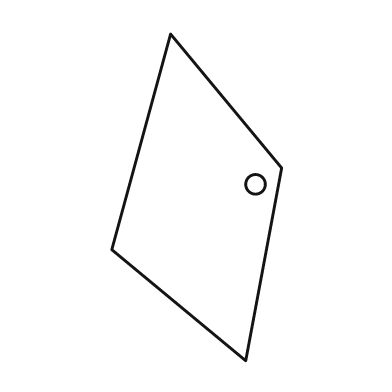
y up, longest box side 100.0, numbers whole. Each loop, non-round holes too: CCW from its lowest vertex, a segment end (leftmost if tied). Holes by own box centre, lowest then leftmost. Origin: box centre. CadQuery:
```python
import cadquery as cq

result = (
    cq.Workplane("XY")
    .moveTo(15.0, -50.0)
    .lineTo(26.0, 9.0)
    .lineTo(-8.0, 50.0)
    .lineTo(-26.0, -16.0)
    .close()
    .moveTo(18.0, 4.0)
    .circle(3.0)
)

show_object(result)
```